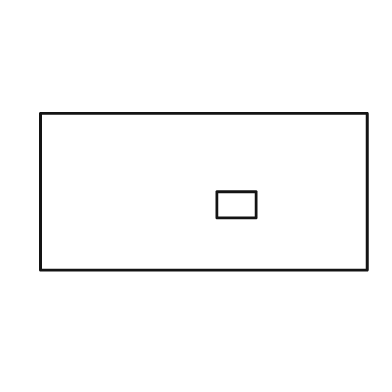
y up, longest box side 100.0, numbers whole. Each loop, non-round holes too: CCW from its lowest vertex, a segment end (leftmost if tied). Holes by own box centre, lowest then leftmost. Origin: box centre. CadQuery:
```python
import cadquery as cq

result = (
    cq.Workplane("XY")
    .moveTo(-50.0, -24.0)
    .lineTo(50.0, -24.0)
    .lineTo(50.0, 24.0)
    .lineTo(-50.0, 24.0)
    .close()
    .moveTo(4.0, -8.0)
    .lineTo(16.0, -8.0)
    .lineTo(16.0, 0.0)
    .lineTo(4.0, 0.0)
    .close()
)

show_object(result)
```